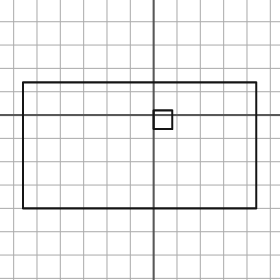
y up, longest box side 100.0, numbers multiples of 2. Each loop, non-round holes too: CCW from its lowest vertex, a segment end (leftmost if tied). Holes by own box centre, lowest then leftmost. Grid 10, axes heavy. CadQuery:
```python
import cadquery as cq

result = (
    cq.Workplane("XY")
    .moveTo(-56.0, -40.0)
    .lineTo(44.0, -40.0)
    .lineTo(44.0, 14.0)
    .lineTo(-56.0, 14.0)
    .close()
    .moveTo(0.0, -6.0)
    .lineTo(8.0, -6.0)
    .lineTo(8.0, 2.0)
    .lineTo(0.0, 2.0)
    .close()
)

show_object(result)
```